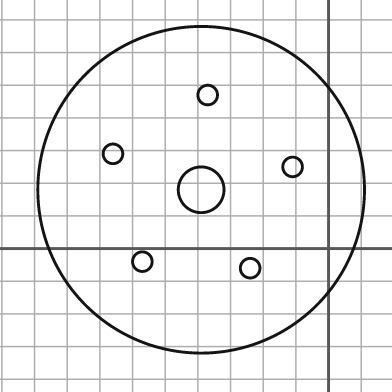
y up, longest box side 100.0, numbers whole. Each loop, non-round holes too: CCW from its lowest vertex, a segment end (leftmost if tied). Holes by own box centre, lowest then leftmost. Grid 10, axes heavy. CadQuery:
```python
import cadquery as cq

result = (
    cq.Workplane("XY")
    .moveTo(-39.0, 18.0)
    .circle(50.0)
    .moveTo(-24.0, -6.0)
    .circle(3.0)
    .moveTo(-57.0, -4.0)
    .circle(3.0)
    .moveTo(-39.0, 18.0)
    .circle(7.0)
    .moveTo(-11.0, 25.0)
    .circle(3.0)
    .moveTo(-66.0, 29.0)
    .circle(3.0)
    .moveTo(-37.0, 47.0)
    .circle(3.0)
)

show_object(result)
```